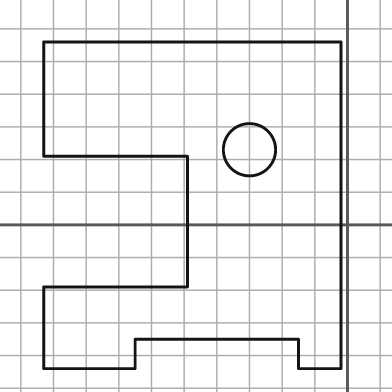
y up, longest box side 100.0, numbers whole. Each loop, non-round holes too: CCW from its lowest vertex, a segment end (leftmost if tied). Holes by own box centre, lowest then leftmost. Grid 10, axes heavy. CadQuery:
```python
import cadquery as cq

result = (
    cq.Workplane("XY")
    .moveTo(-93.0, -44.0)
    .lineTo(-65.0, -44.0)
    .lineTo(-65.0, -35.0)
    .lineTo(-15.0, -35.0)
    .lineTo(-15.0, -44.0)
    .lineTo(-2.0, -44.0)
    .lineTo(-2.0, 56.0)
    .lineTo(-93.0, 56.0)
    .lineTo(-93.0, 21.0)
    .lineTo(-49.0, 21.0)
    .lineTo(-49.0, -19.0)
    .lineTo(-93.0, -19.0)
    .close()
    .moveTo(-30.0, 23.0)
    .circle(8.0)
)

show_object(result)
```